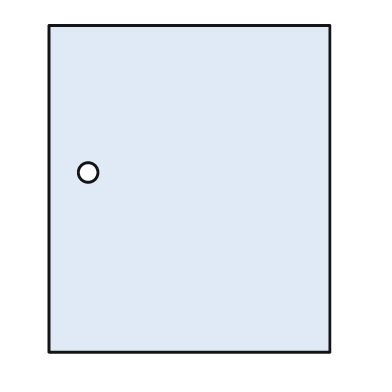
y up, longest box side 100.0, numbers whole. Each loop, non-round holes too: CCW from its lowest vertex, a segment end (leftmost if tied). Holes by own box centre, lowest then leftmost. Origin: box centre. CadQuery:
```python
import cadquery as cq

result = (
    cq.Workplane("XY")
    .moveTo(-43.0, -50.0)
    .lineTo(43.0, -50.0)
    .lineTo(43.0, 50.0)
    .lineTo(-43.0, 50.0)
    .close()
    .moveTo(-31.0, 5.0)
    .circle(3.0)
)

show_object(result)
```